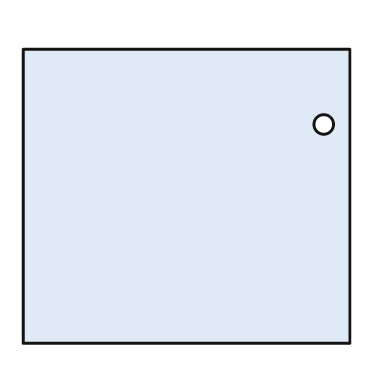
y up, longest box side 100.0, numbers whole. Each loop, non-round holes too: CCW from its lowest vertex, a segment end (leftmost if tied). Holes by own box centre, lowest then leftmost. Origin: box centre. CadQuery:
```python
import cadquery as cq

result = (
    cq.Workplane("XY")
    .moveTo(-50.0, -45.0)
    .lineTo(50.0, -45.0)
    .lineTo(50.0, 45.0)
    .lineTo(-50.0, 45.0)
    .close()
    .moveTo(42.0, 22.0)
    .circle(3.0)
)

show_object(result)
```